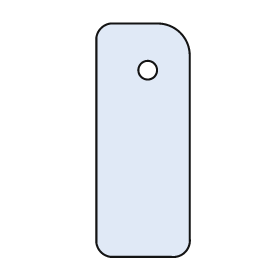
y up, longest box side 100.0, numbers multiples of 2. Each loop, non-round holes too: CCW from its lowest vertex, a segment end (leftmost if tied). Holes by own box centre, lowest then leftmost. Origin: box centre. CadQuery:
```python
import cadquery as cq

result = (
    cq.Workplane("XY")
    .moveTo(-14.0, -50.0)
    .lineTo(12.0, -50.0)
    .threePointArc((18.0, -48.0), (20.0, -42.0))
    .lineTo(20.0, 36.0)
    .threePointArc((16.0, 46.0), (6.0, 50.0))
    .lineTo(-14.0, 50.0)
    .threePointArc((-18.0, 48.0), (-20.0, 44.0))
    .lineTo(-20.0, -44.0)
    .threePointArc((-18.0, -48.0), (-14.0, -50.0))
    .close()
    .moveTo(2.0, 30.0)
    .circle(4.0)
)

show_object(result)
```